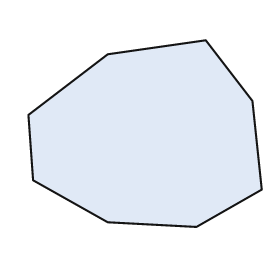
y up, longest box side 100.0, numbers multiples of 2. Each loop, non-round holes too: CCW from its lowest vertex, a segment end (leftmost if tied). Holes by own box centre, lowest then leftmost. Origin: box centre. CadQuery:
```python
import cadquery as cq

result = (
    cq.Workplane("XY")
    .moveTo(22.0, -40.0)
    .lineTo(50.0, -24.0)
    .lineTo(46.0, 14.0)
    .lineTo(26.0, 40.0)
    .lineTo(-16.0, 34.0)
    .lineTo(-50.0, 8.0)
    .lineTo(-48.0, -20.0)
    .lineTo(-16.0, -38.0)
    .close()
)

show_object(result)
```